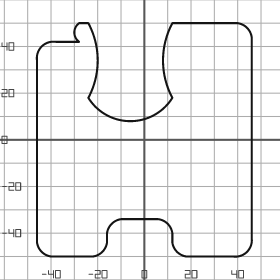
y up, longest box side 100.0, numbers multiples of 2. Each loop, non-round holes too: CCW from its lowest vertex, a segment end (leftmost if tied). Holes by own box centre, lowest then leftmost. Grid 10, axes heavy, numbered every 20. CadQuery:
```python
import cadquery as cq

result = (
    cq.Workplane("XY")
    .moveTo(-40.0, -50.0)
    .lineTo(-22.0, -50.0)
    .threePointArc((-18.0, -48.0), (-16.0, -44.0))
    .lineTo(-16.0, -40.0)
    .threePointArc((-14.0, -36.0), (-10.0, -34.0))
    .lineTo(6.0, -34.0)
    .threePointArc((10.0, -36.0), (12.0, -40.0))
    .lineTo(12.0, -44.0)
    .threePointArc((14.0, -48.0), (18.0, -50.0))
    .lineTo(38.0, -50.0)
    .threePointArc((44.0, -48.0), (46.0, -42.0))
    .lineTo(46.0, 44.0)
    .threePointArc((44.0, 48.0), (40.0, 50.0))
    .lineTo(12.0, 50.0)
    .threePointArc((8.0, 34.0), (12.0, 18.0))
    .threePointArc((-6.0, 8.0), (-24.0, 18.0))
    .threePointArc((-20.0, 34.0), (-24.0, 50.0))
    .lineTo(-28.0, 50.0)
    .threePointArc((-30.0, 46.0), (-28.0, 42.0))
    .lineTo(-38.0, 42.0)
    .threePointArc((-44.0, 40.0), (-46.0, 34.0))
    .lineTo(-46.0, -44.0)
    .threePointArc((-44.0, -48.0), (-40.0, -50.0))
    .close()
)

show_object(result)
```